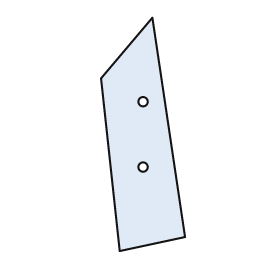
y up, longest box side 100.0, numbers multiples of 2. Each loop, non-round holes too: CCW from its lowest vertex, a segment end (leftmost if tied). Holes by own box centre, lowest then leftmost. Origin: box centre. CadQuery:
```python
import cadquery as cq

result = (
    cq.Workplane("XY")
    .moveTo(-10.0, -50.0)
    .lineTo(18.0, -44.0)
    .lineTo(4.0, 50.0)
    .lineTo(-18.0, 24.0)
    .close()
    .moveTo(0.0, -14.0)
    .circle(2.0)
    .moveTo(0.0, 14.0)
    .circle(2.0)
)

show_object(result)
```